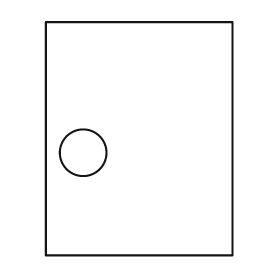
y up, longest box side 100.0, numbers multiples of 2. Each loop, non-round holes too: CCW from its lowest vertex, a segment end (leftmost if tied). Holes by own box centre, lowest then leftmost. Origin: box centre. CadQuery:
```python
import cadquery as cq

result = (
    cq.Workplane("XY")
    .moveTo(-40.0, -50.0)
    .lineTo(40.0, -50.0)
    .lineTo(40.0, 50.0)
    .lineTo(-40.0, 50.0)
    .close()
    .moveTo(-24.0, -6.0)
    .circle(10.0)
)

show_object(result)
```